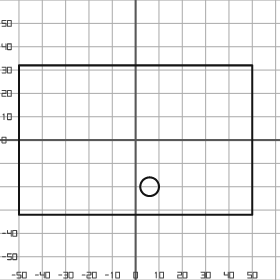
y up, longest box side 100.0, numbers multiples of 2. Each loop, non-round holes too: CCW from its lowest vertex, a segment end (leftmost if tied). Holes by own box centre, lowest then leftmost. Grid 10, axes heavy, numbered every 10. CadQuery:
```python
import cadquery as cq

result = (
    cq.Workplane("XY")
    .moveTo(-50.0, -32.0)
    .lineTo(50.0, -32.0)
    .lineTo(50.0, 32.0)
    .lineTo(-50.0, 32.0)
    .close()
    .moveTo(6.0, -20.0)
    .circle(4.0)
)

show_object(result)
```